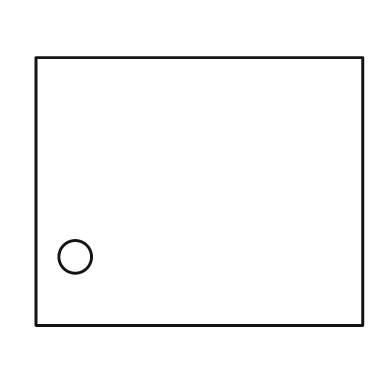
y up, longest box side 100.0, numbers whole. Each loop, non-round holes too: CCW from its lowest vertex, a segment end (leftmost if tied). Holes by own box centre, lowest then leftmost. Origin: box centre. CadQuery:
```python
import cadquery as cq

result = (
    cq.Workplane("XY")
    .moveTo(-50.0, -41.0)
    .lineTo(50.0, -41.0)
    .lineTo(50.0, 41.0)
    .lineTo(-50.0, 41.0)
    .close()
    .moveTo(-38.0, -20.0)
    .circle(5.0)
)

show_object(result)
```